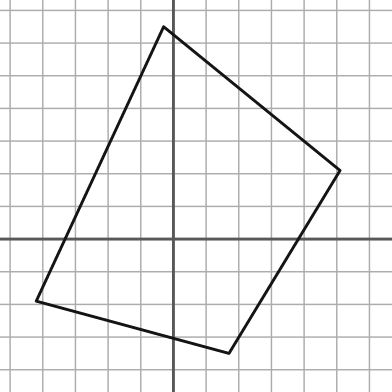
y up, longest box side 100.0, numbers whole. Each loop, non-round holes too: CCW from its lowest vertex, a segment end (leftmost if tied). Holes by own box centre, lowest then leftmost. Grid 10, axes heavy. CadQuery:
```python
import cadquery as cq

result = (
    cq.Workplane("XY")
    .moveTo(17.0, -35.0)
    .lineTo(51.0, 21.0)
    .lineTo(-3.0, 65.0)
    .lineTo(-42.0, -19.0)
    .close()
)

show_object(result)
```